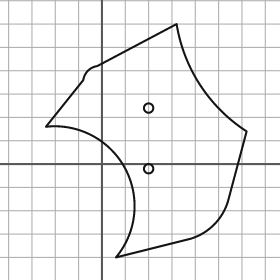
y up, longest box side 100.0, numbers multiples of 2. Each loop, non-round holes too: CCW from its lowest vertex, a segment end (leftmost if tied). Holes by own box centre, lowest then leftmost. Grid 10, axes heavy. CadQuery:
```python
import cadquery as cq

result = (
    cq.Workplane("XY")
    .moveTo(6.0, -40.0)
    .lineTo(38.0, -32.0)
    .threePointArc((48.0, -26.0), (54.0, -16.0))
    .lineTo(62.0, 14.0)
    .threePointArc((42.0, 34.0), (32.0, 60.0))
    .lineTo(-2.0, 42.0)
    .threePointArc((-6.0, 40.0), (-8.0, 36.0))
    .lineTo(-24.0, 16.0)
    .threePointArc((10.0, -2.0), (6.0, -40.0))
    .close()
    .moveTo(20.0, -2.0)
    .circle(2.0)
    .moveTo(20.0, 24.0)
    .circle(2.0)
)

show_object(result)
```